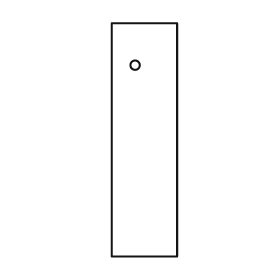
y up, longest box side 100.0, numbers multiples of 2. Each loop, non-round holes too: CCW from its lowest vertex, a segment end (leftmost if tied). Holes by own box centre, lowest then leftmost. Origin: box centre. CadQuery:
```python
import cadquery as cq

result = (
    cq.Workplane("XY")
    .moveTo(-14.0, -50.0)
    .lineTo(14.0, -50.0)
    .lineTo(14.0, 50.0)
    .lineTo(-14.0, 50.0)
    .close()
    .moveTo(-4.0, 32.0)
    .circle(2.0)
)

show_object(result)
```